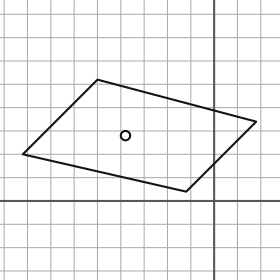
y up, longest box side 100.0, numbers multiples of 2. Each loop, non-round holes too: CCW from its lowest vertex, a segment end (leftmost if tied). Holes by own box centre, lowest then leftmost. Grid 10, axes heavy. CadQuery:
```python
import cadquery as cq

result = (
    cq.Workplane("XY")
    .moveTo(-12.0, 4.0)
    .lineTo(18.0, 34.0)
    .lineTo(-50.0, 52.0)
    .lineTo(-82.0, 20.0)
    .close()
    .moveTo(-38.0, 28.0)
    .circle(2.0)
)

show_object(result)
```